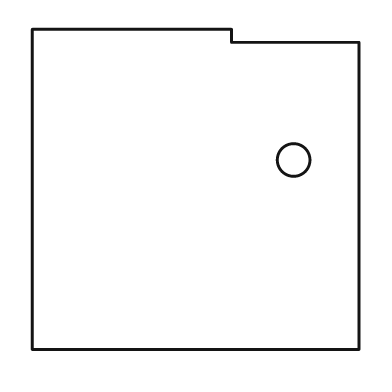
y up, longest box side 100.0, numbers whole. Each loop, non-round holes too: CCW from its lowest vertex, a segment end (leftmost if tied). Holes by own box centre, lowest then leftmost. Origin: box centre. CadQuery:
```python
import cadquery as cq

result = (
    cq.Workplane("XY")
    .moveTo(-50.0, -49.0)
    .lineTo(50.0, -49.0)
    .lineTo(50.0, 45.0)
    .lineTo(11.0, 45.0)
    .lineTo(11.0, 49.0)
    .lineTo(-50.0, 49.0)
    .close()
    .moveTo(30.0, 9.0)
    .circle(5.0)
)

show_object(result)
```